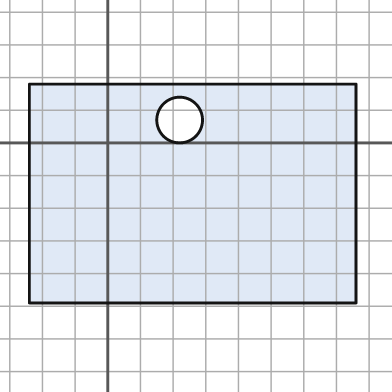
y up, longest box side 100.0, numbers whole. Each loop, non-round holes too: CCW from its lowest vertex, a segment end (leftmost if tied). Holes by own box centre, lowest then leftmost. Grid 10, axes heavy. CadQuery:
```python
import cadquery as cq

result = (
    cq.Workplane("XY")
    .moveTo(-24.0, -49.0)
    .lineTo(76.0, -49.0)
    .lineTo(76.0, 18.0)
    .lineTo(-24.0, 18.0)
    .close()
    .moveTo(22.0, 7.0)
    .circle(7.0)
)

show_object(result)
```